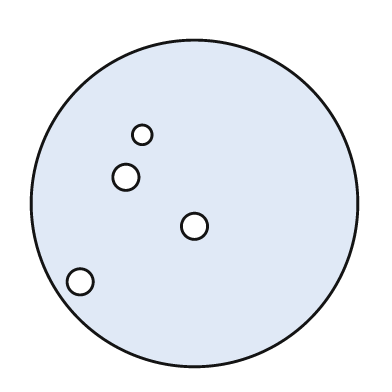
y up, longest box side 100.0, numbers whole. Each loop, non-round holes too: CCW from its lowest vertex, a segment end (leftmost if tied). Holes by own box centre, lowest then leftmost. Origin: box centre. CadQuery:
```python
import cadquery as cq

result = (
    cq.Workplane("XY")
    .moveTo(0.0, 0.0)
    .circle(50.0)
    .moveTo(-35.0, -24.0)
    .circle(4.0)
    .moveTo(0.0, -7.0)
    .circle(4.0)
    .moveTo(-21.0, 8.0)
    .circle(4.0)
    .moveTo(-16.0, 21.0)
    .circle(3.0)
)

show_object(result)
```